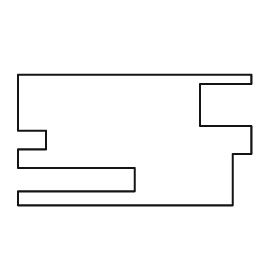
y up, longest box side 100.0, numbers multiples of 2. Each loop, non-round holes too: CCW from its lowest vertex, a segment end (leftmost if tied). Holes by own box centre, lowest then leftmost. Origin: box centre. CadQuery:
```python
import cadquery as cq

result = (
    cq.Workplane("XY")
    .moveTo(-50.0, -28.0)
    .lineTo(42.0, -28.0)
    .lineTo(42.0, -6.0)
    .lineTo(50.0, -6.0)
    .lineTo(50.0, 6.0)
    .lineTo(28.0, 6.0)
    .lineTo(28.0, 24.0)
    .lineTo(50.0, 24.0)
    .lineTo(50.0, 28.0)
    .lineTo(-50.0, 28.0)
    .lineTo(-50.0, 4.0)
    .lineTo(-38.0, 4.0)
    .lineTo(-38.0, -4.0)
    .lineTo(-50.0, -4.0)
    .lineTo(-50.0, -12.0)
    .lineTo(0.0, -12.0)
    .lineTo(0.0, -22.0)
    .lineTo(-50.0, -22.0)
    .close()
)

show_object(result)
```